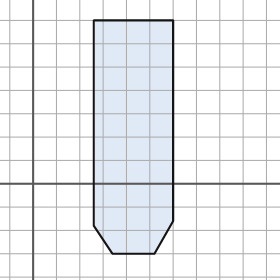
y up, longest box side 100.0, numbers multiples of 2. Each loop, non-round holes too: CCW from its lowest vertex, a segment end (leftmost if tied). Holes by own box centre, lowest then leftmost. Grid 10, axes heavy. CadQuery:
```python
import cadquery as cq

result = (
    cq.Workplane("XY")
    .moveTo(34.0, -30.0)
    .lineTo(52.0, -30.0)
    .lineTo(60.0, -16.0)
    .lineTo(60.0, 70.0)
    .lineTo(26.0, 70.0)
    .lineTo(26.0, -18.0)
    .close()
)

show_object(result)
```